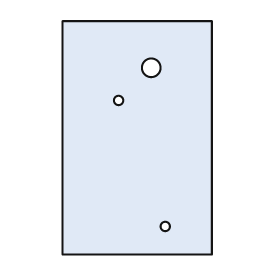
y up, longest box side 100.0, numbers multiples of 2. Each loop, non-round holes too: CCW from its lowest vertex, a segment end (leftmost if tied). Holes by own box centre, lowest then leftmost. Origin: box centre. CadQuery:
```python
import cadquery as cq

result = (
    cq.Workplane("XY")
    .moveTo(-32.0, -50.0)
    .lineTo(32.0, -50.0)
    .lineTo(32.0, 50.0)
    .lineTo(-32.0, 50.0)
    .close()
    .moveTo(12.0, -38.0)
    .circle(2.0)
    .moveTo(-8.0, 16.0)
    .circle(2.0)
    .moveTo(6.0, 30.0)
    .circle(4.0)
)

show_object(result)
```